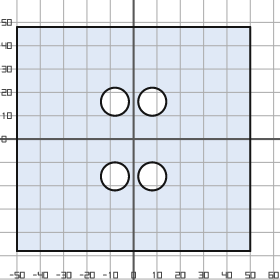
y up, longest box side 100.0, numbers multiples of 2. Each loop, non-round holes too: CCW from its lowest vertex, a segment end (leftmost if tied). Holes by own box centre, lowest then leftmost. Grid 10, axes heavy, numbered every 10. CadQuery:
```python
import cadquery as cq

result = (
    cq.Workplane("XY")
    .moveTo(-50.0, -48.0)
    .lineTo(50.0, -48.0)
    .lineTo(50.0, 48.0)
    .lineTo(-50.0, 48.0)
    .close()
    .moveTo(-8.0, -16.0)
    .circle(6.0)
    .moveTo(8.0, -16.0)
    .circle(6.0)
    .moveTo(-8.0, 16.0)
    .circle(6.0)
    .moveTo(8.0, 16.0)
    .circle(6.0)
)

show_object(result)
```